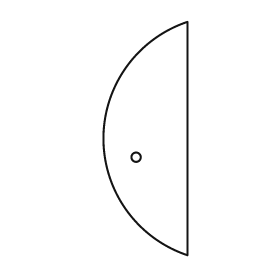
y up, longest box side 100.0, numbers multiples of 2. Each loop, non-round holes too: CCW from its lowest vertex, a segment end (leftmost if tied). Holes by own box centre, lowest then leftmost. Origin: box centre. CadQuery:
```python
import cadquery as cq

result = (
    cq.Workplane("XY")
    .moveTo(18.0, -50.0)
    .lineTo(18.0, 50.0)
    .threePointArc((-18.0, 0.0), (18.0, -50.0))
    .close()
    .moveTo(-4.0, -8.0)
    .circle(2.0)
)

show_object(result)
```